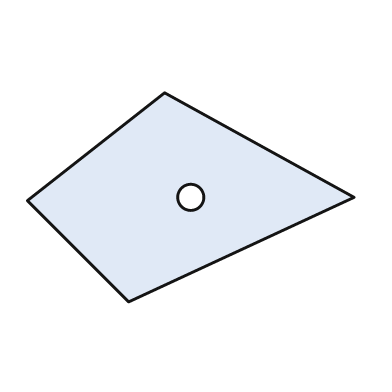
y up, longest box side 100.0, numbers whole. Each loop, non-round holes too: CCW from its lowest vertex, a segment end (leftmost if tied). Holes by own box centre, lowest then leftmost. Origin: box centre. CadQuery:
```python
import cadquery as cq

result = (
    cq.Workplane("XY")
    .moveTo(-19.0, -32.0)
    .lineTo(50.0, 0.0)
    .lineTo(-8.0, 32.0)
    .lineTo(-50.0, -1.0)
    .close()
    .moveTo(0.0, 0.0)
    .circle(4.0)
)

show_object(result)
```